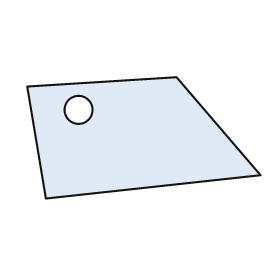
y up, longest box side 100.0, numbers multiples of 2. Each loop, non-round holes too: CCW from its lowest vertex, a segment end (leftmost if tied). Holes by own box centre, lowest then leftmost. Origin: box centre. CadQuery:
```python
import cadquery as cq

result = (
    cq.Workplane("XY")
    .moveTo(-42.0, -26.0)
    .lineTo(50.0, -16.0)
    .lineTo(14.0, 26.0)
    .lineTo(-50.0, 22.0)
    .close()
    .moveTo(-28.0, 12.0)
    .circle(6.0)
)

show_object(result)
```